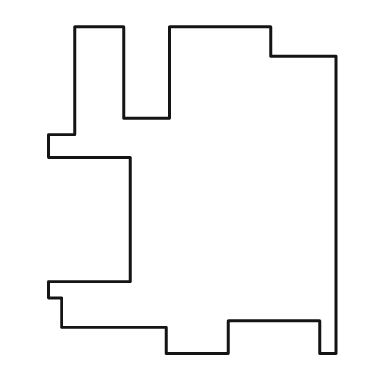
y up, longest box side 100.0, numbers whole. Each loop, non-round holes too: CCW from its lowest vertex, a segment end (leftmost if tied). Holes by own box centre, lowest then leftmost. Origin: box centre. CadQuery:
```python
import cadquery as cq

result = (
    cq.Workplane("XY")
    .moveTo(-8.0, -50.0)
    .lineTo(11.0, -50.0)
    .lineTo(11.0, -40.0)
    .lineTo(39.0, -40.0)
    .lineTo(39.0, -50.0)
    .lineTo(44.0, -50.0)
    .lineTo(44.0, 41.0)
    .lineTo(24.0, 41.0)
    .lineTo(24.0, 50.0)
    .lineTo(-7.0, 50.0)
    .lineTo(-7.0, 22.0)
    .lineTo(-21.0, 22.0)
    .lineTo(-21.0, 50.0)
    .lineTo(-36.0, 50.0)
    .lineTo(-36.0, 17.0)
    .lineTo(-44.0, 17.0)
    .lineTo(-44.0, 10.0)
    .lineTo(-19.0, 10.0)
    .lineTo(-19.0, -28.0)
    .lineTo(-44.0, -28.0)
    .lineTo(-44.0, -33.0)
    .lineTo(-40.0, -33.0)
    .lineTo(-40.0, -42.0)
    .lineTo(-8.0, -42.0)
    .close()
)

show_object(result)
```